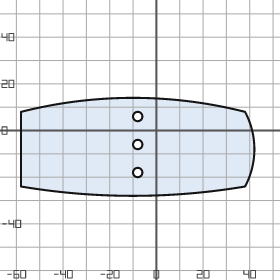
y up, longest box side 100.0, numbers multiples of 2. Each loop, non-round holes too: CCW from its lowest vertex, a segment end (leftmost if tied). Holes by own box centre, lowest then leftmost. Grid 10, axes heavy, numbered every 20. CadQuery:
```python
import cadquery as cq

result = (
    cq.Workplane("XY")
    .moveTo(-58.0, -24.0)
    .threePointArc((-10.0, -28.0), (38.0, -24.0))
    .threePointArc((42.0, -8.0), (38.0, 8.0))
    .threePointArc((-10.0, 14.0), (-58.0, 8.0))
    .close()
    .moveTo(-8.0, -18.0)
    .circle(2.0)
    .moveTo(-8.0, -6.0)
    .circle(2.0)
    .moveTo(-8.0, 6.0)
    .circle(2.0)
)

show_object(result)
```